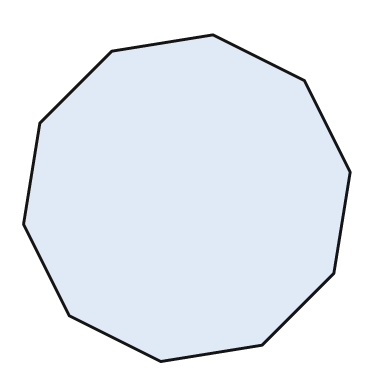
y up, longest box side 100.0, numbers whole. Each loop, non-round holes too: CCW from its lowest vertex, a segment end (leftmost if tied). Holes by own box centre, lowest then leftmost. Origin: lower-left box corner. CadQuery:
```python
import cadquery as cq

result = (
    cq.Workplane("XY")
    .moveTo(42.0, 0.0)
    .lineTo(73.0, 5.0)
    .lineTo(95.0, 27.0)
    .lineTo(100.0, 58.0)
    .lineTo(86.0, 86.0)
    .lineTo(58.0, 100.0)
    .lineTo(27.0, 95.0)
    .lineTo(5.0, 73.0)
    .lineTo(0.0, 42.0)
    .lineTo(14.0, 14.0)
    .close()
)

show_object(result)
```